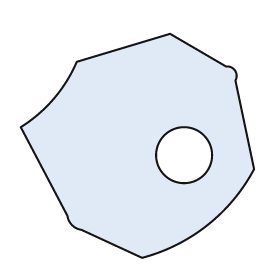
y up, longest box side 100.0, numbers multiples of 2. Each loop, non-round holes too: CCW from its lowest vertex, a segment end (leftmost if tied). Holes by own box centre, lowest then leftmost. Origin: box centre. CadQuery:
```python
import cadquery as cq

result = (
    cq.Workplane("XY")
    .moveTo(2.0, -48.0)
    .threePointArc((30.0, -34.0), (50.0, -10.0))
    .lineTo(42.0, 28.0)
    .threePointArc((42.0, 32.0), (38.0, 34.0))
    .lineTo(14.0, 48.0)
    .lineTo(-26.0, 36.0)
    .threePointArc((-36.0, 20.0), (-50.0, 8.0))
    .lineTo(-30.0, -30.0)
    .threePointArc((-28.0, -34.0), (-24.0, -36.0))
    .close()
    .moveTo(20.0, -4.0)
    .circle(12.0)
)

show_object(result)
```